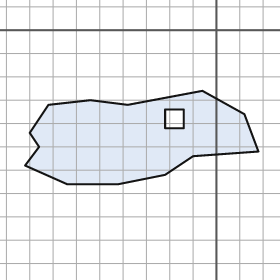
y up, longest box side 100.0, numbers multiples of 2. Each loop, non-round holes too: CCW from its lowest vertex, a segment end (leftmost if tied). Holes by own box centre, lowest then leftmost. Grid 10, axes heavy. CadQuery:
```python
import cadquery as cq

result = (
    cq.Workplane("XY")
    .moveTo(-64.0, -66.0)
    .lineTo(-42.0, -66.0)
    .lineTo(-22.0, -62.0)
    .lineTo(-10.0, -54.0)
    .lineTo(18.0, -52.0)
    .lineTo(12.0, -36.0)
    .lineTo(-6.0, -26.0)
    .lineTo(-38.0, -32.0)
    .lineTo(-54.0, -30.0)
    .lineTo(-72.0, -32.0)
    .lineTo(-80.0, -44.0)
    .lineTo(-76.0, -50.0)
    .lineTo(-82.0, -58.0)
    .close()
    .moveTo(-22.0, -42.0)
    .lineTo(-14.0, -42.0)
    .lineTo(-14.0, -34.0)
    .lineTo(-22.0, -34.0)
    .close()
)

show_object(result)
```